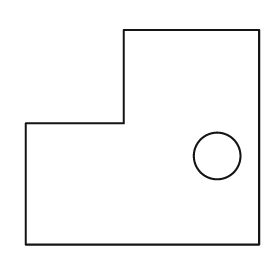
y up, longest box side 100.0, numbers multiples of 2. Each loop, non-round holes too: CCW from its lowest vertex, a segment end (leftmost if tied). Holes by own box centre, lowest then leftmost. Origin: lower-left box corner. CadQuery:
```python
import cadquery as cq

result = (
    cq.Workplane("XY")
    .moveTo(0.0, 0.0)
    .lineTo(100.0, 0.0)
    .lineTo(100.0, 92.0)
    .lineTo(42.0, 92.0)
    .lineTo(42.0, 52.0)
    .lineTo(0.0, 52.0)
    .close()
    .moveTo(82.0, 38.0)
    .circle(10.0)
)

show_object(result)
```